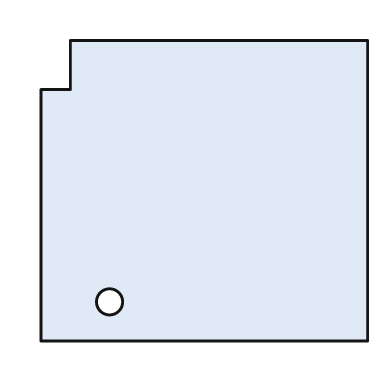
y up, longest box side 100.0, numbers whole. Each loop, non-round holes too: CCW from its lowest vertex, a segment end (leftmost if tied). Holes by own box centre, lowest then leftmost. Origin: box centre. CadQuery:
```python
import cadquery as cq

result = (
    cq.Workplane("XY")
    .moveTo(-50.0, -46.0)
    .lineTo(50.0, -46.0)
    .lineTo(50.0, 46.0)
    .lineTo(-41.0, 46.0)
    .lineTo(-41.0, 31.0)
    .lineTo(-50.0, 31.0)
    .close()
    .moveTo(-29.0, -34.0)
    .circle(4.0)
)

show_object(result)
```